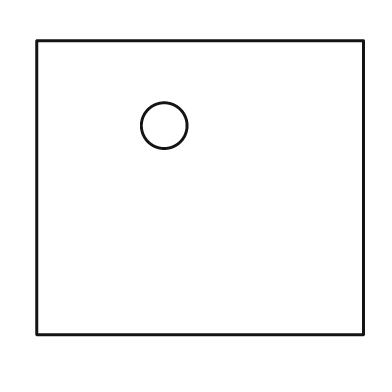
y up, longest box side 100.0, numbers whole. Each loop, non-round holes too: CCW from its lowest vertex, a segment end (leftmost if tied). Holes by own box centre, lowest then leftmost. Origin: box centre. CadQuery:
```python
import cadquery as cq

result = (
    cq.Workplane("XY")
    .moveTo(-50.0, -45.0)
    .lineTo(50.0, -45.0)
    .lineTo(50.0, 45.0)
    .lineTo(-50.0, 45.0)
    .close()
    .moveTo(-11.0, 19.0)
    .circle(7.0)
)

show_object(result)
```